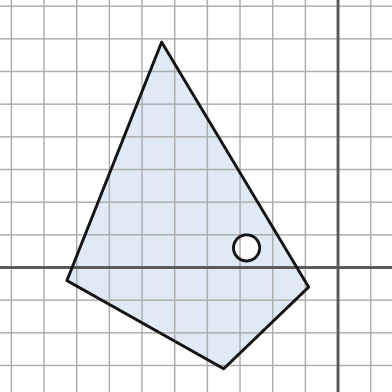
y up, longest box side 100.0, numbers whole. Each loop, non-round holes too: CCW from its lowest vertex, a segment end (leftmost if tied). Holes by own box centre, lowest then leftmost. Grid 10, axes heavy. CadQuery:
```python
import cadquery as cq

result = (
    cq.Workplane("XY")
    .moveTo(-35.0, -31.0)
    .lineTo(-9.0, -6.0)
    .lineTo(-54.0, 69.0)
    .lineTo(-83.0, -4.0)
    .close()
    .moveTo(-28.0, 6.0)
    .circle(4.0)
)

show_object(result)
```